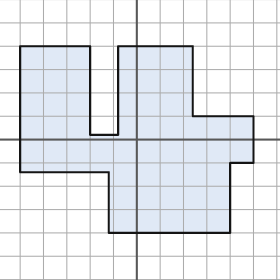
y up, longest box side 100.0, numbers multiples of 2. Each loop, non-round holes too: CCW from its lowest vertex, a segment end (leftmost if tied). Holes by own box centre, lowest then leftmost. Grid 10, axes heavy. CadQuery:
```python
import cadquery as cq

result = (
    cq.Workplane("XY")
    .moveTo(-12.0, -40.0)
    .lineTo(40.0, -40.0)
    .lineTo(40.0, -10.0)
    .lineTo(50.0, -10.0)
    .lineTo(50.0, 10.0)
    .lineTo(24.0, 10.0)
    .lineTo(24.0, 40.0)
    .lineTo(-8.0, 40.0)
    .lineTo(-8.0, 2.0)
    .lineTo(-20.0, 2.0)
    .lineTo(-20.0, 40.0)
    .lineTo(-50.0, 40.0)
    .lineTo(-50.0, -14.0)
    .lineTo(-12.0, -14.0)
    .close()
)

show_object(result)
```